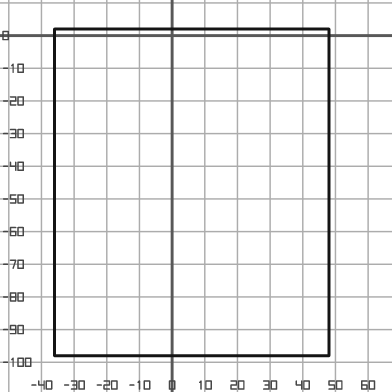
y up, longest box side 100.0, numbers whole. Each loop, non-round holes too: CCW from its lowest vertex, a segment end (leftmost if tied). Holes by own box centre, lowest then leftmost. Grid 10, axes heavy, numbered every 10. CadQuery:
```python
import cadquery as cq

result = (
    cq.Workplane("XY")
    .moveTo(-36.0, -98.0)
    .lineTo(48.0, -98.0)
    .lineTo(48.0, 2.0)
    .lineTo(-36.0, 2.0)
    .close()
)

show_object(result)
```